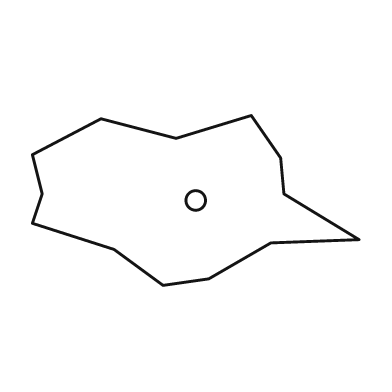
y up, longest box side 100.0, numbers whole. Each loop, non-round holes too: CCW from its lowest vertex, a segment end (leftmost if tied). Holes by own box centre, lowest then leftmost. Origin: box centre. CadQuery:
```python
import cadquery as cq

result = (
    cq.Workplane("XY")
    .moveTo(-10.0, -26.0)
    .lineTo(4.0, -24.0)
    .lineTo(23.0, -13.0)
    .lineTo(50.0, -12.0)
    .lineTo(27.0, 2.0)
    .lineTo(26.0, 13.0)
    .lineTo(17.0, 26.0)
    .lineTo(-6.0, 19.0)
    .lineTo(-29.0, 25.0)
    .lineTo(-50.0, 14.0)
    .lineTo(-47.0, 2.0)
    .lineTo(-50.0, -7.0)
    .lineTo(-25.0, -15.0)
    .close()
    .moveTo(0.0, 0.0)
    .circle(3.0)
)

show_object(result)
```